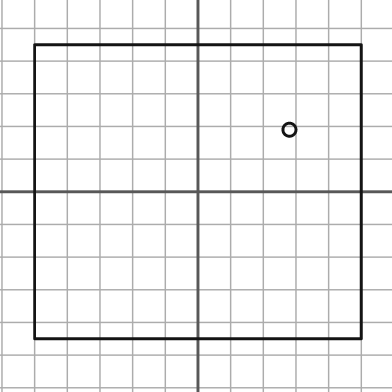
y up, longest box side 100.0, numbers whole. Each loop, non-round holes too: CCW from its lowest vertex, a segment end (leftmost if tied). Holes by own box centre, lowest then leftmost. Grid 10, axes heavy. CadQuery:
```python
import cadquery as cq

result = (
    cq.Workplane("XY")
    .moveTo(-50.0, -45.0)
    .lineTo(50.0, -45.0)
    .lineTo(50.0, 45.0)
    .lineTo(-50.0, 45.0)
    .close()
    .moveTo(28.0, 19.0)
    .circle(2.0)
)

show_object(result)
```